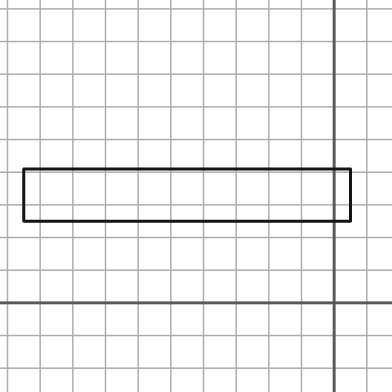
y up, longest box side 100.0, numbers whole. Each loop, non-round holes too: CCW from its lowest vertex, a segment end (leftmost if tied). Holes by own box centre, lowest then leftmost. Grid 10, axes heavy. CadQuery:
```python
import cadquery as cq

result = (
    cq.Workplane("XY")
    .moveTo(-95.0, 25.0)
    .lineTo(5.0, 25.0)
    .lineTo(5.0, 41.0)
    .lineTo(-95.0, 41.0)
    .close()
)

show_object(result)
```